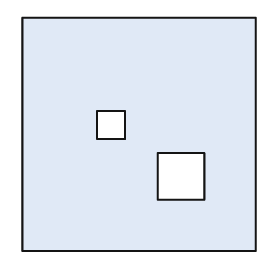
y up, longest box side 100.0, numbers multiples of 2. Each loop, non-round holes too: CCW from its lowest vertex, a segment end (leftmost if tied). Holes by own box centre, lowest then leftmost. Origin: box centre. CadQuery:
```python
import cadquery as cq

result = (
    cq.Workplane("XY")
    .moveTo(-50.0, -50.0)
    .lineTo(50.0, -50.0)
    .lineTo(50.0, 50.0)
    .lineTo(-50.0, 50.0)
    .close()
    .moveTo(8.0, -28.0)
    .lineTo(28.0, -28.0)
    .lineTo(28.0, -8.0)
    .lineTo(8.0, -8.0)
    .close()
    .moveTo(-18.0, -2.0)
    .lineTo(-6.0, -2.0)
    .lineTo(-6.0, 10.0)
    .lineTo(-18.0, 10.0)
    .close()
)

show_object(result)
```